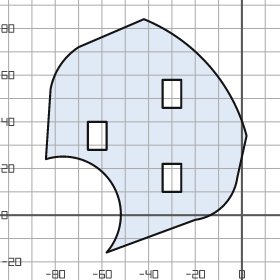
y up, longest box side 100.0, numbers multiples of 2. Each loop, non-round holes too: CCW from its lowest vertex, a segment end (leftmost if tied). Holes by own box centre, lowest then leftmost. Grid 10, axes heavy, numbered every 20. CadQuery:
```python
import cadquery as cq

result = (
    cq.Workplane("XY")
    .moveTo(-58.0, -16.0)
    .lineTo(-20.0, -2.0)
    .threePointArc((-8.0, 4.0), (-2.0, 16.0))
    .lineTo(2.0, 34.0)
    .threePointArc((-14.0, 64.0), (-42.0, 84.0))
    .lineTo(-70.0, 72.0)
    .threePointArc((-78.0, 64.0), (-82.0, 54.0))
    .lineTo(-84.0, 24.0)
    .threePointArc((-56.0, 14.0), (-58.0, -16.0))
    .close()
    .moveTo(-34.0, 10.0)
    .lineTo(-26.0, 10.0)
    .lineTo(-26.0, 22.0)
    .lineTo(-34.0, 22.0)
    .close()
    .moveTo(-66.0, 28.0)
    .lineTo(-58.0, 28.0)
    .lineTo(-58.0, 40.0)
    .lineTo(-66.0, 40.0)
    .close()
    .moveTo(-34.0, 46.0)
    .lineTo(-26.0, 46.0)
    .lineTo(-26.0, 58.0)
    .lineTo(-34.0, 58.0)
    .close()
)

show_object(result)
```